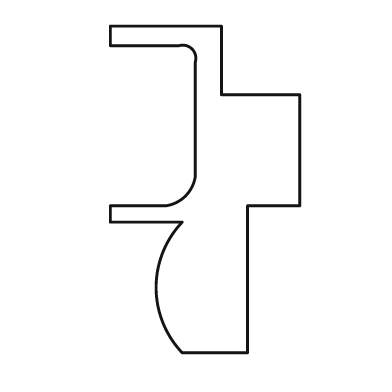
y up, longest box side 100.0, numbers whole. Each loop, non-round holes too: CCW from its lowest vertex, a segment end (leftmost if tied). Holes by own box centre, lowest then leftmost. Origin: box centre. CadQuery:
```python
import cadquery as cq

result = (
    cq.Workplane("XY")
    .moveTo(-7.0, -50.0)
    .lineTo(13.0, -50.0)
    .lineTo(13.0, -5.0)
    .lineTo(29.0, -5.0)
    .lineTo(29.0, 29.0)
    .lineTo(5.0, 29.0)
    .lineTo(5.0, 50.0)
    .lineTo(-29.0, 50.0)
    .lineTo(-29.0, 44.0)
    .lineTo(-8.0, 44.0)
    .threePointArc((-4.0, 43.0), (-3.0, 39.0))
    .lineTo(-3.0, 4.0)
    .threePointArc((-6.0, -2.0), (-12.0, -5.0))
    .lineTo(-29.0, -5.0)
    .lineTo(-29.0, -10.0)
    .lineTo(-7.0, -10.0)
    .threePointArc((-15.0, -30.0), (-7.0, -50.0))
    .close()
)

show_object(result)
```